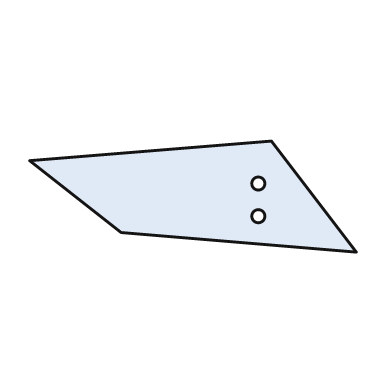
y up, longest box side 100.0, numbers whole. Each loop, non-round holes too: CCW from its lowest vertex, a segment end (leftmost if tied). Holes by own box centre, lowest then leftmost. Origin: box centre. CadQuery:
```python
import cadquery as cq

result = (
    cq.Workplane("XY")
    .moveTo(50.0, -17.0)
    .lineTo(24.0, 17.0)
    .lineTo(-50.0, 11.0)
    .lineTo(-22.0, -11.0)
    .close()
    .moveTo(20.0, -6.0)
    .circle(2.0)
    .moveTo(20.0, 4.0)
    .circle(2.0)
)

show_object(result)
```